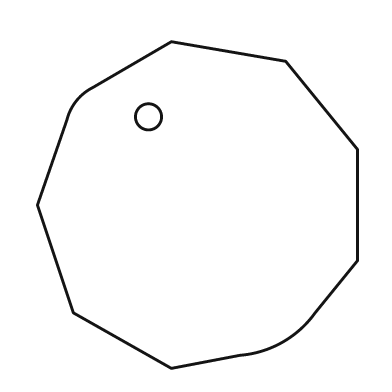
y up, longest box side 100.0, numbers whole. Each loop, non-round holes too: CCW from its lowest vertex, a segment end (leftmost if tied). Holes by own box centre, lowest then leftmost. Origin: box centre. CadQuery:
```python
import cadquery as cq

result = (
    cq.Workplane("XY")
    .moveTo(-8.0, -50.0)
    .lineTo(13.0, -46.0)
    .threePointArc((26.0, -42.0), (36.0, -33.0))
    .lineTo(49.0, -17.0)
    .lineTo(49.0, 17.0)
    .lineTo(27.0, 44.0)
    .lineTo(-8.0, 50.0)
    .lineTo(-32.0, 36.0)
    .threePointArc((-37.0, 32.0), (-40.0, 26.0))
    .lineTo(-49.0, 0.0)
    .lineTo(-38.0, -33.0)
    .close()
    .moveTo(-15.0, 27.0)
    .circle(4.0)
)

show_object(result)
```